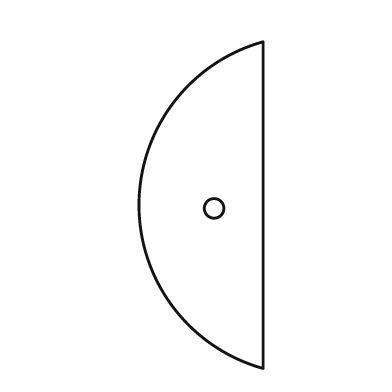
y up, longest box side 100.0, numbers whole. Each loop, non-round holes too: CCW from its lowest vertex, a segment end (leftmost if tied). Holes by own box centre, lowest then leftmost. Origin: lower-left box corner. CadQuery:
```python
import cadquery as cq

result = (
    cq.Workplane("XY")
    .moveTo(38.0, 0.0)
    .lineTo(38.0, 100.0)
    .threePointArc((0.0, 50.0), (38.0, 0.0))
    .close()
    .moveTo(23.0, 49.0)
    .circle(3.0)
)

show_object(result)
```